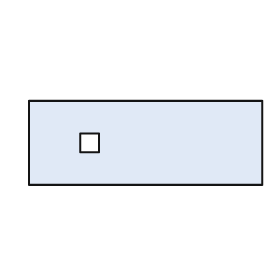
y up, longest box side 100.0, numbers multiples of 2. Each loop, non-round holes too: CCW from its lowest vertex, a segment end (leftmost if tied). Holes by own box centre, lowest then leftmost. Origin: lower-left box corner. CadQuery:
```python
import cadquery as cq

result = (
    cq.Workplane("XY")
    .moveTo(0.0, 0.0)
    .lineTo(100.0, 0.0)
    .lineTo(100.0, 36.0)
    .lineTo(0.0, 36.0)
    .close()
    .moveTo(22.0, 14.0)
    .lineTo(30.0, 14.0)
    .lineTo(30.0, 22.0)
    .lineTo(22.0, 22.0)
    .close()
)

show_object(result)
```